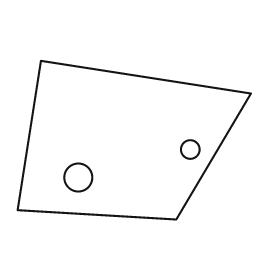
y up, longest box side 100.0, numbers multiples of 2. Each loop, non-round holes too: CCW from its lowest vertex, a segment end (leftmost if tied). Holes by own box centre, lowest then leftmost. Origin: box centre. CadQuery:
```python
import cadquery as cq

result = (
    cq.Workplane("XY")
    .moveTo(18.0, -34.0)
    .lineTo(50.0, 20.0)
    .lineTo(-40.0, 34.0)
    .lineTo(-50.0, -30.0)
    .close()
    .moveTo(-24.0, -16.0)
    .circle(6.0)
    .moveTo(24.0, -4.0)
    .circle(4.0)
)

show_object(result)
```